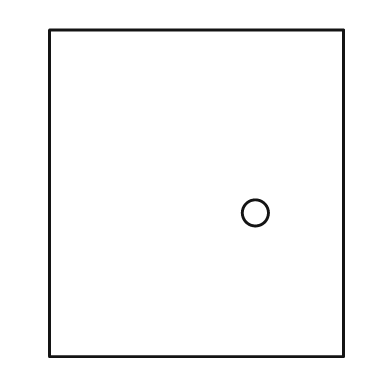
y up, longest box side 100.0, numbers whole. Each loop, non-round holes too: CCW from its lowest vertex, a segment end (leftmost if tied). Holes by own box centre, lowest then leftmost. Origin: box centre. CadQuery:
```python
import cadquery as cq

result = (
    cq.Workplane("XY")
    .moveTo(-45.0, -50.0)
    .lineTo(45.0, -50.0)
    .lineTo(45.0, 50.0)
    .lineTo(-45.0, 50.0)
    .close()
    .moveTo(18.0, -6.0)
    .circle(4.0)
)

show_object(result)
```